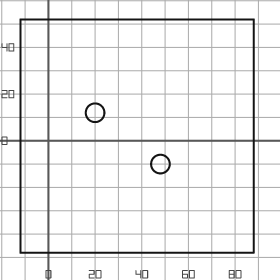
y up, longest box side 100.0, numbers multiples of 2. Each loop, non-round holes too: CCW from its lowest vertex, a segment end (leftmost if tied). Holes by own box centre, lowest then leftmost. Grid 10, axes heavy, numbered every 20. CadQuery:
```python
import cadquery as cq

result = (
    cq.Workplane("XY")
    .moveTo(-12.0, -48.0)
    .lineTo(88.0, -48.0)
    .lineTo(88.0, 52.0)
    .lineTo(-12.0, 52.0)
    .close()
    .moveTo(48.0, -10.0)
    .circle(4.0)
    .moveTo(20.0, 12.0)
    .circle(4.0)
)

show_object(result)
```